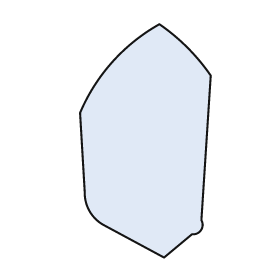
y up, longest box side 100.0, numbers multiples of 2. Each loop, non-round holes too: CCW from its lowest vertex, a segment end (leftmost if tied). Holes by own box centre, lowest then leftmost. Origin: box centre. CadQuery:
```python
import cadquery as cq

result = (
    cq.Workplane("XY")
    .moveTo(8.0, -50.0)
    .lineTo(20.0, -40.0)
    .threePointArc((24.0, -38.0), (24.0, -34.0))
    .lineTo(28.0, 28.0)
    .threePointArc((18.0, 40.0), (6.0, 50.0))
    .threePointArc((-14.0, 34.0), (-28.0, 12.0))
    .lineTo(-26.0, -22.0)
    .threePointArc((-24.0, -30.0), (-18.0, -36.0))
    .close()
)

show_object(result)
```